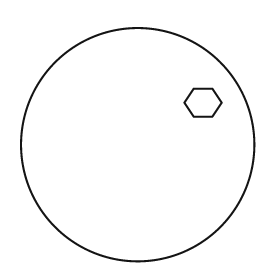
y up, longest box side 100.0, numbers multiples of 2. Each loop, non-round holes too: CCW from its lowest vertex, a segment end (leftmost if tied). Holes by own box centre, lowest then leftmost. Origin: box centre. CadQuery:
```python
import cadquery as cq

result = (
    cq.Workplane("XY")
    .moveTo(0.0, 0.0)
    .circle(50.0)
    .moveTo(24.0, 12.0)
    .lineTo(32.0, 12.0)
    .lineTo(36.0, 18.0)
    .lineTo(32.0, 24.0)
    .lineTo(24.0, 24.0)
    .lineTo(20.0, 18.0)
    .close()
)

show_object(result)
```